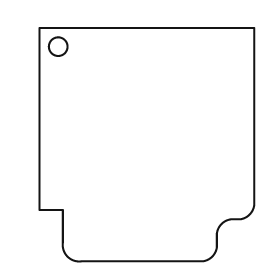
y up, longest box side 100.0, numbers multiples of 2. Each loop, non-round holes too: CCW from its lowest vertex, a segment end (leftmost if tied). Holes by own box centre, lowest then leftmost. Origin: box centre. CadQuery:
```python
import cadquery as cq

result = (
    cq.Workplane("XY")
    .moveTo(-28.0, -50.0)
    .lineTo(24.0, -50.0)
    .threePointArc((28.0, -48.0), (30.0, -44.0))
    .lineTo(30.0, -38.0)
    .threePointArc((32.0, -34.0), (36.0, -32.0))
    .lineTo(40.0, -32.0)
    .threePointArc((44.0, -30.0), (46.0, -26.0))
    .lineTo(46.0, 50.0)
    .lineTo(-46.0, 50.0)
    .lineTo(-46.0, -28.0)
    .lineTo(-36.0, -28.0)
    .lineTo(-36.0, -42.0)
    .threePointArc((-34.0, -48.0), (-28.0, -50.0))
    .close()
    .moveTo(-38.0, 42.0)
    .circle(4.0)
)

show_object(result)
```